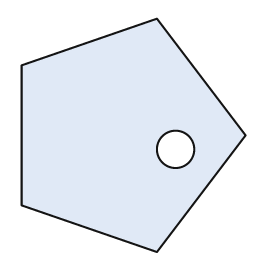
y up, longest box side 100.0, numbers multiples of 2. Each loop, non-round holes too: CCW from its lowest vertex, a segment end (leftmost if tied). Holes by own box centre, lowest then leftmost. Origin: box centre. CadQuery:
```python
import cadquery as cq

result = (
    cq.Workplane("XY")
    .moveTo(10.0, -50.0)
    .lineTo(48.0, 0.0)
    .lineTo(10.0, 50.0)
    .lineTo(-48.0, 30.0)
    .lineTo(-48.0, -30.0)
    .close()
    .moveTo(18.0, -6.0)
    .circle(8.0)
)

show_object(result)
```